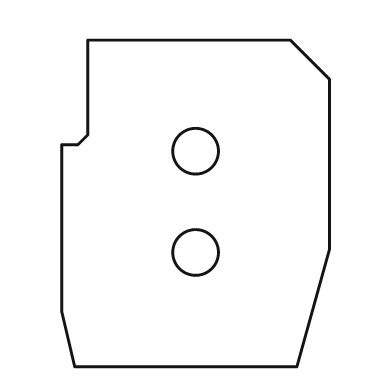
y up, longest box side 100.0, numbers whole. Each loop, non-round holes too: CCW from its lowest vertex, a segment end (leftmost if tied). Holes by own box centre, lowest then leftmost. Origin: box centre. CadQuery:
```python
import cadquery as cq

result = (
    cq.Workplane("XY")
    .moveTo(-37.0, -50.0)
    .lineTo(31.0, -50.0)
    .lineTo(41.0, -14.0)
    .lineTo(41.0, 38.0)
    .lineTo(29.0, 50.0)
    .lineTo(-33.0, 50.0)
    .lineTo(-33.0, 21.0)
    .lineTo(-36.0, 18.0)
    .lineTo(-41.0, 18.0)
    .lineTo(-41.0, -33.0)
    .close()
    .moveTo(0.0, -15.0)
    .circle(7.0)
    .moveTo(0.0, 16.0)
    .circle(7.0)
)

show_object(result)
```